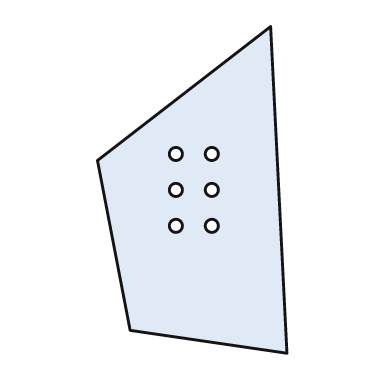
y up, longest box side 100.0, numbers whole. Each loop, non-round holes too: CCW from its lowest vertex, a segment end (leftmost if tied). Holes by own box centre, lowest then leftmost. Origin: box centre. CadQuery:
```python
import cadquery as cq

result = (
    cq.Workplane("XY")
    .moveTo(29.0, -50.0)
    .lineTo(24.0, 50.0)
    .lineTo(-29.0, 9.0)
    .lineTo(-19.0, -43.0)
    .close()
    .moveTo(-5.0, -11.0)
    .circle(2.0)
    .moveTo(6.0, -11.0)
    .circle(2.0)
    .moveTo(-5.0, 0.0)
    .circle(2.0)
    .moveTo(6.0, 0.0)
    .circle(2.0)
    .moveTo(-5.0, 11.0)
    .circle(2.0)
    .moveTo(6.0, 11.0)
    .circle(2.0)
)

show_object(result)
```